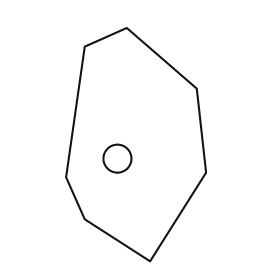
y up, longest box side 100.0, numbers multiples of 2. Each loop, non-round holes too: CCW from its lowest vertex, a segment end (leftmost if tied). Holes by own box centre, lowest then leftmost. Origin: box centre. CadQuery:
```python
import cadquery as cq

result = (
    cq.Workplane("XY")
    .moveTo(6.0, -50.0)
    .lineTo(30.0, -12.0)
    .lineTo(26.0, 24.0)
    .lineTo(-4.0, 50.0)
    .lineTo(-22.0, 42.0)
    .lineTo(-30.0, -14.0)
    .lineTo(-22.0, -32.0)
    .close()
    .moveTo(-8.0, -6.0)
    .circle(6.0)
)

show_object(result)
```